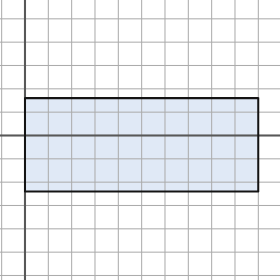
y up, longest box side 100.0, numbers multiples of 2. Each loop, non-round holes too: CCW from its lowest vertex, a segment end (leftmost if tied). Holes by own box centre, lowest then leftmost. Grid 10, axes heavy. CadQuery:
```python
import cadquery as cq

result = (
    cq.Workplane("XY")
    .moveTo(0.0, -24.0)
    .lineTo(100.0, -24.0)
    .lineTo(100.0, 16.0)
    .lineTo(0.0, 16.0)
    .close()
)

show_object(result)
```